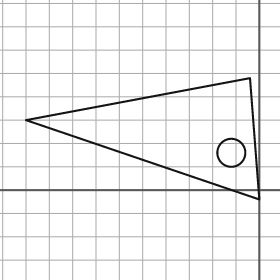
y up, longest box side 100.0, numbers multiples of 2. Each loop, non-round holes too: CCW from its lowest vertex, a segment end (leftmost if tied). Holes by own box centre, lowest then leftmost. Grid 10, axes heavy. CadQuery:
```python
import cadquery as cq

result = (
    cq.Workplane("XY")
    .moveTo(0.0, -4.0)
    .lineTo(-4.0, 48.0)
    .lineTo(-100.0, 30.0)
    .close()
    .moveTo(-12.0, 16.0)
    .circle(6.0)
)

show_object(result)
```